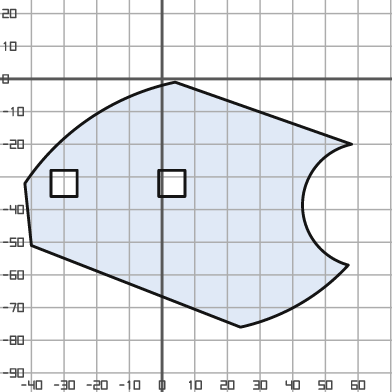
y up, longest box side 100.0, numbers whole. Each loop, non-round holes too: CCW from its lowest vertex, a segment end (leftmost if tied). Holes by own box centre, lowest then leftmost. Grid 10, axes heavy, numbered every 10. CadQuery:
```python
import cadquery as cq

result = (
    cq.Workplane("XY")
    .moveTo(24.0, -76.0)
    .threePointArc((42.0, -69.0), (57.0, -57.0))
    .threePointArc((43.0, -38.0), (58.0, -20.0))
    .lineTo(4.0, -1.0)
    .threePointArc((-22.0, -12.0), (-42.0, -32.0))
    .lineTo(-40.0, -51.0)
    .close()
    .moveTo(-34.0, -36.0)
    .lineTo(-26.0, -36.0)
    .lineTo(-26.0, -28.0)
    .lineTo(-34.0, -28.0)
    .close()
    .moveTo(-1.0, -36.0)
    .lineTo(7.0, -36.0)
    .lineTo(7.0, -28.0)
    .lineTo(-1.0, -28.0)
    .close()
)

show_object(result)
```